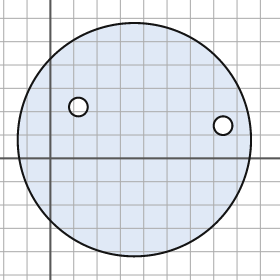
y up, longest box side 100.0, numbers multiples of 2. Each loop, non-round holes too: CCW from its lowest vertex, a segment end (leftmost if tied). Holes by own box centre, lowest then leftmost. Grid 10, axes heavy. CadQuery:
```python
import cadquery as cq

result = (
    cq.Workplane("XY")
    .moveTo(36.0, 8.0)
    .circle(50.0)
    .moveTo(74.0, 14.0)
    .circle(4.0)
    .moveTo(12.0, 22.0)
    .circle(4.0)
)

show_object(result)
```